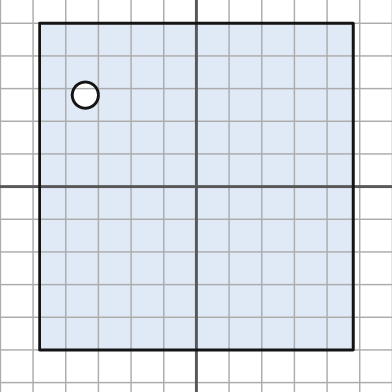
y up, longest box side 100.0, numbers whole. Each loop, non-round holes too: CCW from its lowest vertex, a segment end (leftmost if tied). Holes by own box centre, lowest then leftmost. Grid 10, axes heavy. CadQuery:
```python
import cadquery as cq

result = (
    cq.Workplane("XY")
    .moveTo(-48.0, -50.0)
    .lineTo(48.0, -50.0)
    .lineTo(48.0, 50.0)
    .lineTo(-48.0, 50.0)
    .close()
    .moveTo(-34.0, 28.0)
    .circle(4.0)
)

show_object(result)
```